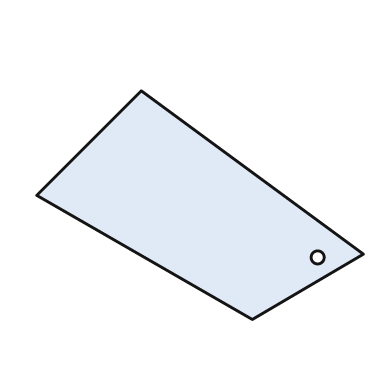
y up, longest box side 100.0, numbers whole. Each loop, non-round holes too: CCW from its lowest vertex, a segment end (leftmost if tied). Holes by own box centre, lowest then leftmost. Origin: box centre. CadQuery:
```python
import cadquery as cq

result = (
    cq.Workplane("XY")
    .moveTo(16.0, -35.0)
    .lineTo(50.0, -15.0)
    .lineTo(-18.0, 35.0)
    .lineTo(-50.0, 3.0)
    .close()
    .moveTo(36.0, -16.0)
    .circle(2.0)
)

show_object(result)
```